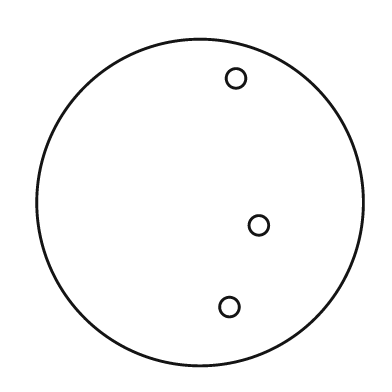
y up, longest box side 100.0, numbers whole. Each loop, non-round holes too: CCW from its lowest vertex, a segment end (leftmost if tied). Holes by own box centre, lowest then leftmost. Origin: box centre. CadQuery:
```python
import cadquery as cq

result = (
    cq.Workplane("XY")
    .moveTo(0.0, 0.0)
    .circle(50.0)
    .moveTo(9.0, -32.0)
    .circle(3.0)
    .moveTo(18.0, -7.0)
    .circle(3.0)
    .moveTo(11.0, 38.0)
    .circle(3.0)
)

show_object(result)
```